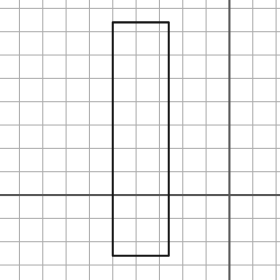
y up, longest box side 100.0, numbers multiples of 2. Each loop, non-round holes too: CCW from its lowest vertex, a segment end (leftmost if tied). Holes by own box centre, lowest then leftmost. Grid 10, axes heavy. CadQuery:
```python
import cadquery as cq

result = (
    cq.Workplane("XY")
    .moveTo(-50.0, -26.0)
    .lineTo(-26.0, -26.0)
    .lineTo(-26.0, 74.0)
    .lineTo(-50.0, 74.0)
    .close()
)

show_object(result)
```